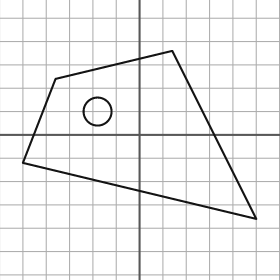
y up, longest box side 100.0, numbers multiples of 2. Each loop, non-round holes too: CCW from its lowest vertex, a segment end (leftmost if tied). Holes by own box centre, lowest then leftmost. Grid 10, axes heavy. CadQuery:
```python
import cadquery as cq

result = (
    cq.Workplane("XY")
    .moveTo(50.0, -36.0)
    .lineTo(14.0, 36.0)
    .lineTo(-36.0, 24.0)
    .lineTo(-50.0, -12.0)
    .close()
    .moveTo(-18.0, 10.0)
    .circle(6.0)
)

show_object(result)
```